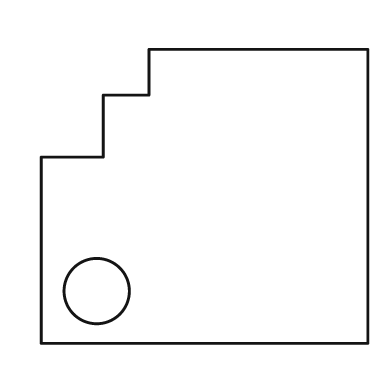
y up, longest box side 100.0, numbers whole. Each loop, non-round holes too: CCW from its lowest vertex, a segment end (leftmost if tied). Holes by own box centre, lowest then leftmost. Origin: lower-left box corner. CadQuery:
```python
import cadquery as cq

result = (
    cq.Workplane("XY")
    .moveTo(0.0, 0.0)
    .lineTo(100.0, 0.0)
    .lineTo(100.0, 90.0)
    .lineTo(33.0, 90.0)
    .lineTo(33.0, 76.0)
    .lineTo(19.0, 76.0)
    .lineTo(19.0, 57.0)
    .lineTo(0.0, 57.0)
    .close()
    .moveTo(17.0, 16.0)
    .circle(10.0)
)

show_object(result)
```